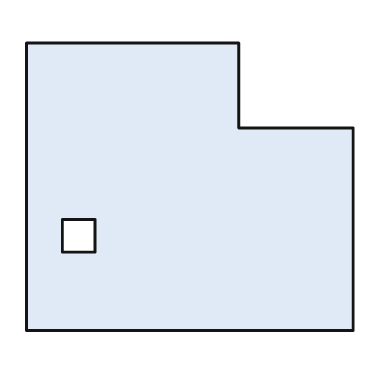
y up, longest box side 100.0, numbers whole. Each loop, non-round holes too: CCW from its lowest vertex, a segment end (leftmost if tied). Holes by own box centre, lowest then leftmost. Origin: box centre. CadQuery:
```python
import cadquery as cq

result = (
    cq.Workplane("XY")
    .moveTo(-50.0, -44.0)
    .lineTo(50.0, -44.0)
    .lineTo(50.0, 18.0)
    .lineTo(15.0, 18.0)
    .lineTo(15.0, 44.0)
    .lineTo(-50.0, 44.0)
    .close()
    .moveTo(-39.0, -20.0)
    .lineTo(-29.0, -20.0)
    .lineTo(-29.0, -10.0)
    .lineTo(-39.0, -10.0)
    .close()
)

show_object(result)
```